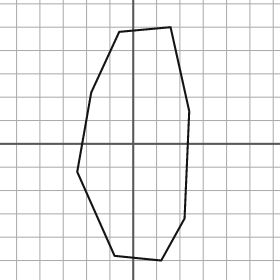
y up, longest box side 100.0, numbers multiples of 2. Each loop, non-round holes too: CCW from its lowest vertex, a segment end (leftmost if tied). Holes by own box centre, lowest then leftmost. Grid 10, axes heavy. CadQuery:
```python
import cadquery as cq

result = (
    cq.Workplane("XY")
    .moveTo(12.0, -50.0)
    .lineTo(22.0, -32.0)
    .lineTo(24.0, 14.0)
    .lineTo(16.0, 50.0)
    .lineTo(-6.0, 48.0)
    .lineTo(-18.0, 22.0)
    .lineTo(-24.0, -12.0)
    .lineTo(-8.0, -48.0)
    .close()
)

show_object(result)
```